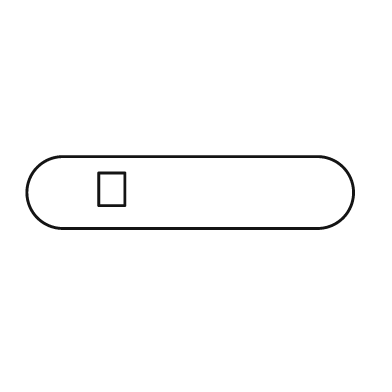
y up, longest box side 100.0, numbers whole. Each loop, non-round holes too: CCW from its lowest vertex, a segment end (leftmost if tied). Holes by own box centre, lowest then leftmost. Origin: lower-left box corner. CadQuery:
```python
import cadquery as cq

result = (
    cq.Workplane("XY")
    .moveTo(11.0, 0.0)
    .lineTo(89.0, 0.0)
    .threePointArc((100.0, 11.0), (89.0, 22.0))
    .lineTo(11.0, 22.0)
    .threePointArc((0.0, 11.0), (11.0, 0.0))
    .close()
    .moveTo(22.0, 7.0)
    .lineTo(30.0, 7.0)
    .lineTo(30.0, 17.0)
    .lineTo(22.0, 17.0)
    .close()
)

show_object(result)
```